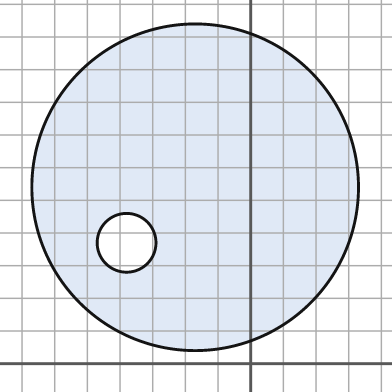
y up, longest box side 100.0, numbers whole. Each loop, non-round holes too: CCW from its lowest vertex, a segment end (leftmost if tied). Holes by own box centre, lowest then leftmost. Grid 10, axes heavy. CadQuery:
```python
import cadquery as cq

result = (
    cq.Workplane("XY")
    .moveTo(-17.0, 54.0)
    .circle(50.0)
    .moveTo(-38.0, 37.0)
    .circle(9.0)
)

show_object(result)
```